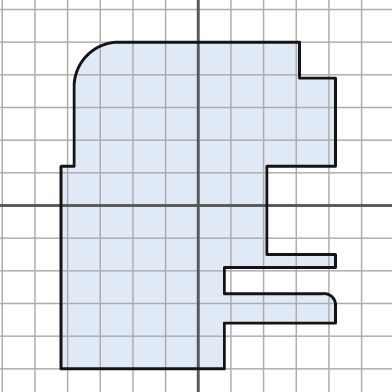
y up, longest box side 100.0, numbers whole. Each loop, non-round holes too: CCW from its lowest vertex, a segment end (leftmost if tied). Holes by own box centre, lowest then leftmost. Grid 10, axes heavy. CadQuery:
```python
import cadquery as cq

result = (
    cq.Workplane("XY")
    .moveTo(-42.0, -50.0)
    .lineTo(8.0, -50.0)
    .lineTo(8.0, -36.0)
    .lineTo(42.0, -36.0)
    .lineTo(42.0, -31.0)
    .threePointArc((41.0, -28.0), (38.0, -27.0))
    .lineTo(8.0, -27.0)
    .lineTo(8.0, -19.0)
    .lineTo(42.0, -19.0)
    .lineTo(42.0, -15.0)
    .lineTo(21.0, -15.0)
    .lineTo(21.0, 12.0)
    .lineTo(42.0, 12.0)
    .lineTo(42.0, 39.0)
    .lineTo(31.0, 39.0)
    .lineTo(31.0, 50.0)
    .lineTo(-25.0, 50.0)
    .threePointArc((-34.0, 46.0), (-38.0, 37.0))
    .lineTo(-38.0, 12.0)
    .lineTo(-42.0, 12.0)
    .close()
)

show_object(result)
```